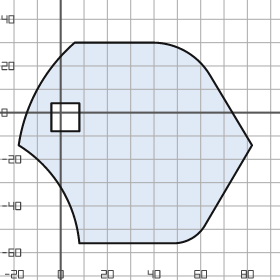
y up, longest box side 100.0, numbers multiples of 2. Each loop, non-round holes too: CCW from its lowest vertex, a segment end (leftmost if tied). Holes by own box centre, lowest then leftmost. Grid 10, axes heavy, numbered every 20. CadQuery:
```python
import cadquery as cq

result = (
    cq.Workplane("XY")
    .moveTo(8.0, -56.0)
    .lineTo(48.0, -56.0)
    .threePointArc((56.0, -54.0), (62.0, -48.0))
    .lineTo(82.0, -14.0)
    .lineTo(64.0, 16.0)
    .threePointArc((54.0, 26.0), (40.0, 30.0))
    .lineTo(6.0, 30.0)
    .threePointArc((-10.0, 10.0), (-18.0, -14.0))
    .threePointArc((0.0, -32.0), (8.0, -56.0))
    .close()
    .moveTo(-4.0, -8.0)
    .lineTo(8.0, -8.0)
    .lineTo(8.0, 4.0)
    .lineTo(-4.0, 4.0)
    .close()
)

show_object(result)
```